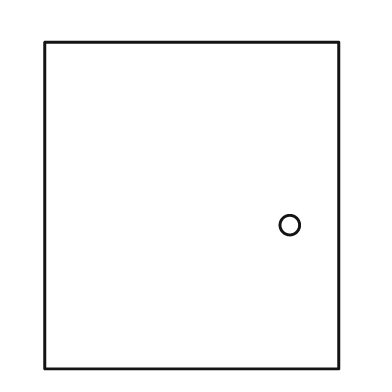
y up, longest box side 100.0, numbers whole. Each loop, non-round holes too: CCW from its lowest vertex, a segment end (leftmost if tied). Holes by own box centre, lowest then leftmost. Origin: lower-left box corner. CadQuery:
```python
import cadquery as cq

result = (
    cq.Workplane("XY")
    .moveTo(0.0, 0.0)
    .lineTo(90.0, 0.0)
    .lineTo(90.0, 100.0)
    .lineTo(0.0, 100.0)
    .close()
    .moveTo(75.0, 44.0)
    .circle(3.0)
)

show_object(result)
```